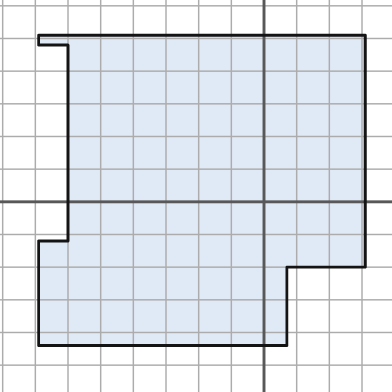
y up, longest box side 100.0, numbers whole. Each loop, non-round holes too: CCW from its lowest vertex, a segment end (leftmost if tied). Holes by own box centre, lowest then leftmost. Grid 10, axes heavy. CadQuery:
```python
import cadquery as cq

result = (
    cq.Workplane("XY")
    .moveTo(-69.0, -44.0)
    .lineTo(7.0, -44.0)
    .lineTo(7.0, -20.0)
    .lineTo(31.0, -20.0)
    .lineTo(31.0, 51.0)
    .lineTo(-69.0, 51.0)
    .lineTo(-69.0, 48.0)
    .lineTo(-60.0, 48.0)
    .lineTo(-60.0, -12.0)
    .lineTo(-69.0, -12.0)
    .close()
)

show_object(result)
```